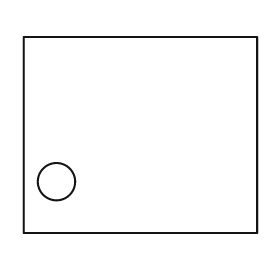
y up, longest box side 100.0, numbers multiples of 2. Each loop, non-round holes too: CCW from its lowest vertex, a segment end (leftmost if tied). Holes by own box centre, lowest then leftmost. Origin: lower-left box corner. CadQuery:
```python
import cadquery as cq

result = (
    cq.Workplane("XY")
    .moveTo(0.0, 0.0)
    .lineTo(100.0, 0.0)
    .lineTo(100.0, 84.0)
    .lineTo(0.0, 84.0)
    .close()
    .moveTo(14.0, 22.0)
    .circle(8.0)
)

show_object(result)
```